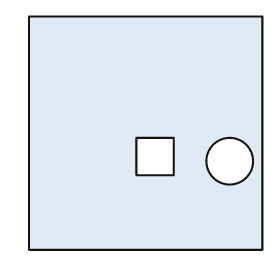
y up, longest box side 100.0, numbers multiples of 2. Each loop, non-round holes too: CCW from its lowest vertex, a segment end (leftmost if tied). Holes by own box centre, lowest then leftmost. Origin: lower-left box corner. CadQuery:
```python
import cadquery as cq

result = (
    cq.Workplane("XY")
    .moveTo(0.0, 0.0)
    .lineTo(100.0, 0.0)
    .lineTo(100.0, 100.0)
    .lineTo(0.0, 100.0)
    .close()
    .moveTo(86.0, 38.0)
    .circle(10.0)
    .moveTo(46.0, 32.0)
    .lineTo(62.0, 32.0)
    .lineTo(62.0, 48.0)
    .lineTo(46.0, 48.0)
    .close()
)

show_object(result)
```